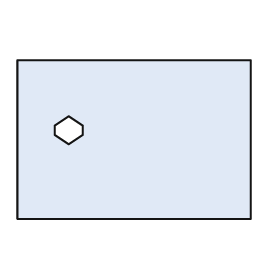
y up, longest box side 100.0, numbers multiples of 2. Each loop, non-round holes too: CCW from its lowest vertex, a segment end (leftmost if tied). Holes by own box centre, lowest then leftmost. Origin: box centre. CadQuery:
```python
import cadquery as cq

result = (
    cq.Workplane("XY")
    .moveTo(-50.0, -34.0)
    .lineTo(50.0, -34.0)
    .lineTo(50.0, 34.0)
    .lineTo(-50.0, 34.0)
    .close()
    .moveTo(-28.0, -2.0)
    .lineTo(-22.0, 2.0)
    .lineTo(-22.0, 6.0)
    .lineTo(-28.0, 10.0)
    .lineTo(-34.0, 6.0)
    .lineTo(-34.0, 2.0)
    .close()
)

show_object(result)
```